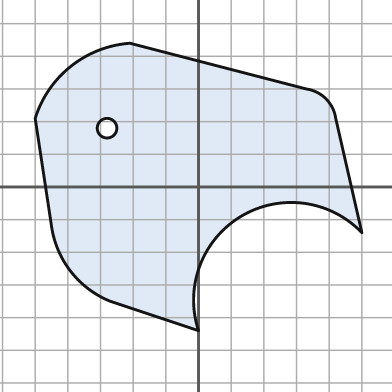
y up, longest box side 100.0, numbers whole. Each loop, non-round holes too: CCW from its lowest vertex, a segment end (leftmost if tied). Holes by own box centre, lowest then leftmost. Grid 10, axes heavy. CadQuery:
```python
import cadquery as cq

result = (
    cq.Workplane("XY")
    .moveTo(0.0, -44.0)
    .threePointArc((13.0, -9.0), (50.0, -14.0))
    .lineTo(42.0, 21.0)
    .threePointArc((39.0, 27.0), (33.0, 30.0))
    .lineTo(-21.0, 44.0)
    .threePointArc((-39.0, 37.0), (-50.0, 21.0))
    .lineTo(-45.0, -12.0)
    .threePointArc((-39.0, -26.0), (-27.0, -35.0))
    .close()
    .moveTo(-28.0, 18.0)
    .circle(3.0)
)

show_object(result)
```